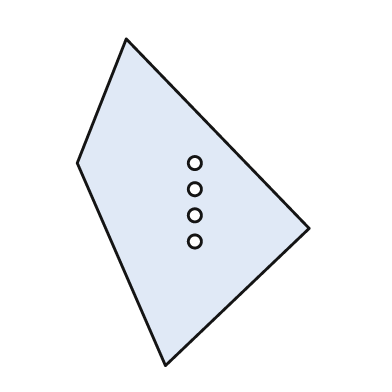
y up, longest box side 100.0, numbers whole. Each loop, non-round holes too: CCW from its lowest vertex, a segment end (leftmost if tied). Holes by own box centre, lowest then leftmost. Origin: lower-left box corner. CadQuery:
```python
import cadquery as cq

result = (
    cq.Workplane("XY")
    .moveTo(27.0, 0.0)
    .lineTo(71.0, 42.0)
    .lineTo(15.0, 100.0)
    .lineTo(0.0, 62.0)
    .close()
    .moveTo(36.0, 38.0)
    .circle(2.0)
    .moveTo(36.0, 46.0)
    .circle(2.0)
    .moveTo(36.0, 54.0)
    .circle(2.0)
    .moveTo(36.0, 62.0)
    .circle(2.0)
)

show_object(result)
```